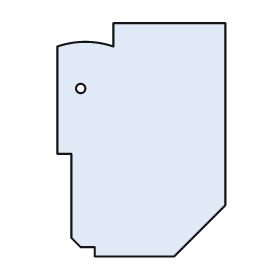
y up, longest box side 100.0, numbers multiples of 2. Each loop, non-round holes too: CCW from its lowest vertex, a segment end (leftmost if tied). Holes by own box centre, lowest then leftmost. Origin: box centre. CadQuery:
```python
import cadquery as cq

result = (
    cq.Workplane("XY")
    .moveTo(-20.0, -50.0)
    .lineTo(14.0, -50.0)
    .lineTo(36.0, -28.0)
    .lineTo(36.0, 50.0)
    .lineTo(-12.0, 50.0)
    .lineTo(-12.0, 40.0)
    .threePointArc((-24.0, 42.0), (-36.0, 40.0))
    .lineTo(-36.0, -6.0)
    .lineTo(-30.0, -6.0)
    .lineTo(-30.0, -42.0)
    .lineTo(-26.0, -46.0)
    .lineTo(-20.0, -46.0)
    .close()
    .moveTo(-26.0, 22.0)
    .circle(2.0)
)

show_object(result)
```